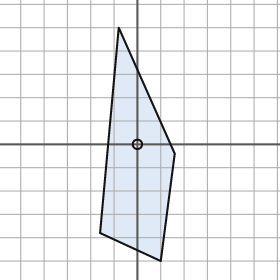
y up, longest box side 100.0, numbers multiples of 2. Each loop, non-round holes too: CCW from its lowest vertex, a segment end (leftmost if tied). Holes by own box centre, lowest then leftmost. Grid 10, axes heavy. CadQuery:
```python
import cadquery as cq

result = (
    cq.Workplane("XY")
    .moveTo(10.0, -50.0)
    .lineTo(16.0, -4.0)
    .lineTo(-8.0, 50.0)
    .lineTo(-16.0, -38.0)
    .close()
    .moveTo(0.0, 0.0)
    .circle(2.0)
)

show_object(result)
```